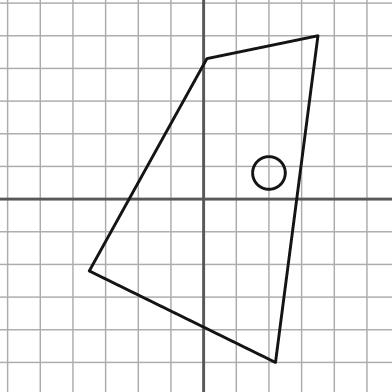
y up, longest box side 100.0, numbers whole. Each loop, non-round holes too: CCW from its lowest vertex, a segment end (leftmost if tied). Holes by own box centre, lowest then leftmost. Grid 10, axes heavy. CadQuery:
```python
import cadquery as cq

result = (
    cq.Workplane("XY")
    .moveTo(22.0, -50.0)
    .lineTo(35.0, 50.0)
    .lineTo(1.0, 43.0)
    .lineTo(-35.0, -22.0)
    .close()
    .moveTo(20.0, 8.0)
    .circle(5.0)
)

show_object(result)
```